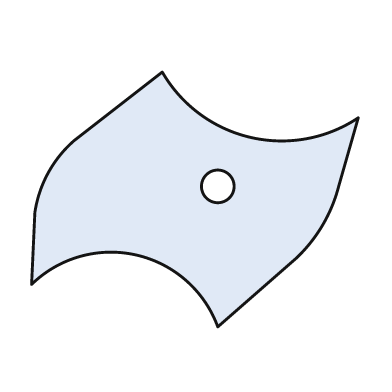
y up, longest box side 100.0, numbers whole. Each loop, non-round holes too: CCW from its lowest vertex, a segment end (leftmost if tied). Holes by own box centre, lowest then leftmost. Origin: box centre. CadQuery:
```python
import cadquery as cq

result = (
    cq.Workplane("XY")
    .moveTo(7.0, -39.0)
    .lineTo(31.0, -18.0)
    .threePointArc((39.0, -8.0), (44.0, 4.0))
    .lineTo(50.0, 25.0)
    .threePointArc((17.0, 19.0), (-10.0, 39.0))
    .lineTo(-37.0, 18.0)
    .threePointArc((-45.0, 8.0), (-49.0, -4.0))
    .lineTo(-50.0, -26.0)
    .threePointArc((-18.0, -17.0), (7.0, -39.0))
    .close()
    .moveTo(7.0, 4.0)
    .circle(5.0)
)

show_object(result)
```